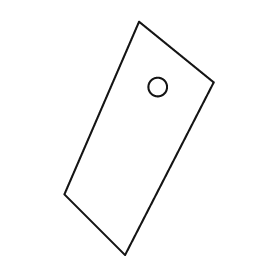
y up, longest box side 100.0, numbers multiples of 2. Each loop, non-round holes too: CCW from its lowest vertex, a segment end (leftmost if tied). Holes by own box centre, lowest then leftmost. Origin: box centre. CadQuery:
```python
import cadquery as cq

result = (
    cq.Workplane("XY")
    .moveTo(-6.0, -50.0)
    .lineTo(32.0, 24.0)
    .lineTo(0.0, 50.0)
    .lineTo(-32.0, -24.0)
    .close()
    .moveTo(8.0, 22.0)
    .circle(4.0)
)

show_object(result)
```